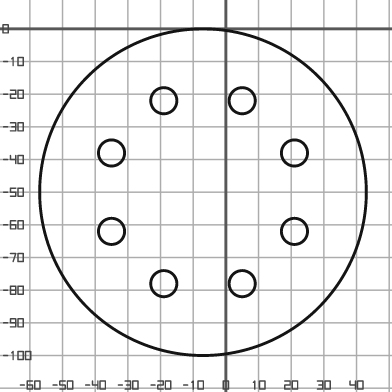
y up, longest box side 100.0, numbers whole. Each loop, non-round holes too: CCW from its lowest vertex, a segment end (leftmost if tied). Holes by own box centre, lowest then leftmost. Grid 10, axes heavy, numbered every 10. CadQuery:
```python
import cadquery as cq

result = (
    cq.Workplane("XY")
    .moveTo(-7.0, -50.0)
    .circle(50.0)
    .moveTo(-19.0, -78.0)
    .circle(4.0)
    .moveTo(5.0, -78.0)
    .circle(4.0)
    .moveTo(-35.0, -62.0)
    .circle(4.0)
    .moveTo(21.0, -62.0)
    .circle(4.0)
    .moveTo(-35.0, -38.0)
    .circle(4.0)
    .moveTo(21.0, -38.0)
    .circle(4.0)
    .moveTo(-19.0, -22.0)
    .circle(4.0)
    .moveTo(5.0, -22.0)
    .circle(4.0)
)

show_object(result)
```